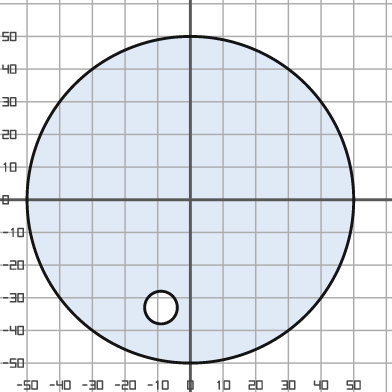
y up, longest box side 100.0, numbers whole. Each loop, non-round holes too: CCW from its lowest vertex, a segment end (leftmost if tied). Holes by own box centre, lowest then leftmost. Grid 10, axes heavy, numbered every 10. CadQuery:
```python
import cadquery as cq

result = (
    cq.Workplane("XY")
    .moveTo(0.0, 0.0)
    .circle(50.0)
    .moveTo(-9.0, -33.0)
    .circle(5.0)
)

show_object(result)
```